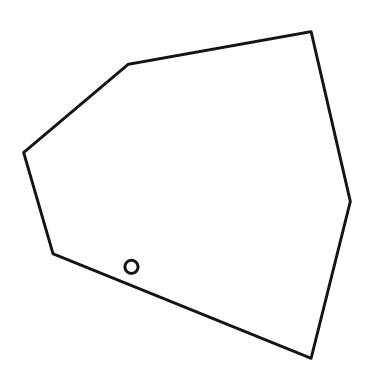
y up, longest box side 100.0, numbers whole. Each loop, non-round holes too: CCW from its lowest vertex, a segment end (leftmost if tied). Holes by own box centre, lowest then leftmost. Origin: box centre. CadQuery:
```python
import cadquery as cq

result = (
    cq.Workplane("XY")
    .moveTo(38.0, -50.0)
    .lineTo(50.0, -2.0)
    .lineTo(38.0, 50.0)
    .lineTo(-18.0, 40.0)
    .lineTo(-50.0, 13.0)
    .lineTo(-41.0, -18.0)
    .close()
    .moveTo(-17.0, -22.0)
    .circle(2.0)
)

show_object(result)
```